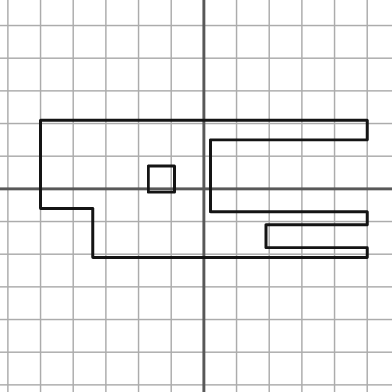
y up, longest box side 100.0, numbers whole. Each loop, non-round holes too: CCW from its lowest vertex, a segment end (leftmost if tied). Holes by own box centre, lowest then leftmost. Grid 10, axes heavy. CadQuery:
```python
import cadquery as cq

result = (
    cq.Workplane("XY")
    .moveTo(-34.0, -21.0)
    .lineTo(50.0, -21.0)
    .lineTo(50.0, -18.0)
    .lineTo(19.0, -18.0)
    .lineTo(19.0, -11.0)
    .lineTo(50.0, -11.0)
    .lineTo(50.0, -7.0)
    .lineTo(2.0, -7.0)
    .lineTo(2.0, 15.0)
    .lineTo(50.0, 15.0)
    .lineTo(50.0, 21.0)
    .lineTo(-50.0, 21.0)
    .lineTo(-50.0, -6.0)
    .lineTo(-34.0, -6.0)
    .close()
    .moveTo(-17.0, -1.0)
    .lineTo(-9.0, -1.0)
    .lineTo(-9.0, 7.0)
    .lineTo(-17.0, 7.0)
    .close()
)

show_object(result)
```